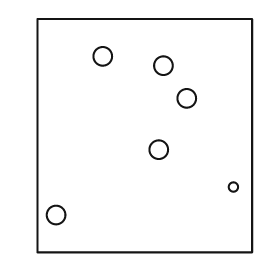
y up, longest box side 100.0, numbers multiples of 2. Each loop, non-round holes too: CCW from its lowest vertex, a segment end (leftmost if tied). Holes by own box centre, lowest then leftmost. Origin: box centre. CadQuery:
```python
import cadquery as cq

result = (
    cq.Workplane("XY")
    .moveTo(-46.0, -50.0)
    .lineTo(46.0, -50.0)
    .lineTo(46.0, 50.0)
    .lineTo(-46.0, 50.0)
    .close()
    .moveTo(-38.0, -34.0)
    .circle(4.0)
    .moveTo(38.0, -22.0)
    .circle(2.0)
    .moveTo(6.0, -6.0)
    .circle(4.0)
    .moveTo(18.0, 16.0)
    .circle(4.0)
    .moveTo(8.0, 30.0)
    .circle(4.0)
    .moveTo(-18.0, 34.0)
    .circle(4.0)
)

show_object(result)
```